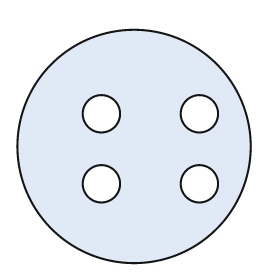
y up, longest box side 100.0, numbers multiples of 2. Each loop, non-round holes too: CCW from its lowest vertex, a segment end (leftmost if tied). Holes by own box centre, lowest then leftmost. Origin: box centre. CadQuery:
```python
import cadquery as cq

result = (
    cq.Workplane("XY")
    .moveTo(0.0, 0.0)
    .circle(50.0)
    .moveTo(-14.0, -16.0)
    .circle(8.0)
    .moveTo(28.0, -16.0)
    .circle(8.0)
    .moveTo(-14.0, 14.0)
    .circle(8.0)
    .moveTo(28.0, 14.0)
    .circle(8.0)
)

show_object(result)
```